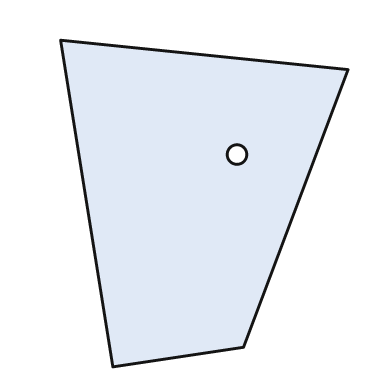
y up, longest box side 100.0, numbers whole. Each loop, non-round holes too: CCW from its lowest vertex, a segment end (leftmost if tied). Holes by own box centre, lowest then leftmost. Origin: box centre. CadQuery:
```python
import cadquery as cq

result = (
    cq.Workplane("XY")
    .moveTo(-28.0, -50.0)
    .lineTo(12.0, -44.0)
    .lineTo(44.0, 41.0)
    .lineTo(-44.0, 50.0)
    .close()
    .moveTo(10.0, 15.0)
    .circle(3.0)
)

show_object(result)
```